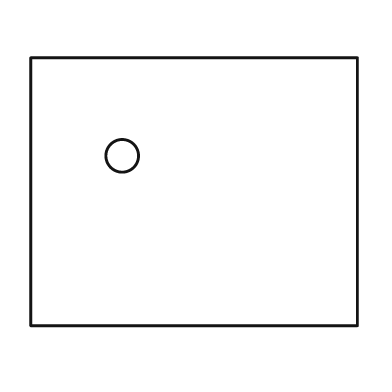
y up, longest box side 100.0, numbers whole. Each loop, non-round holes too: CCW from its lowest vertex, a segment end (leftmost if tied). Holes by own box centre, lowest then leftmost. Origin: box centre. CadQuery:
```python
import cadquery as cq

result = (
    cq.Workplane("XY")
    .moveTo(-50.0, -41.0)
    .lineTo(50.0, -41.0)
    .lineTo(50.0, 41.0)
    .lineTo(-50.0, 41.0)
    .close()
    .moveTo(-22.0, 11.0)
    .circle(5.0)
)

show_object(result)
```